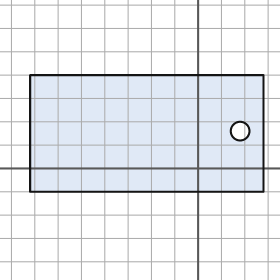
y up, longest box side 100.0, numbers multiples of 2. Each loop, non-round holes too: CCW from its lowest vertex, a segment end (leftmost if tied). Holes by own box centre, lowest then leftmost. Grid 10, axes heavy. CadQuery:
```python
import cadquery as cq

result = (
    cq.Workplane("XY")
    .moveTo(-72.0, -10.0)
    .lineTo(28.0, -10.0)
    .lineTo(28.0, 40.0)
    .lineTo(-72.0, 40.0)
    .close()
    .moveTo(18.0, 16.0)
    .circle(4.0)
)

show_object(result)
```